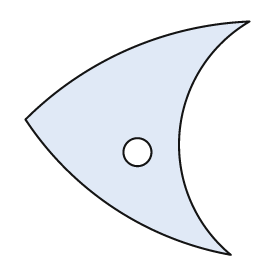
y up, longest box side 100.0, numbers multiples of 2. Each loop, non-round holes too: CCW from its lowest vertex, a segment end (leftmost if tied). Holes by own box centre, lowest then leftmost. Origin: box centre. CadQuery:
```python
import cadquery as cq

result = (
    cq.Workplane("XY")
    .moveTo(40.0, -50.0)
    .threePointArc((18.0, 2.0), (48.0, 50.0))
    .threePointArc((-4.0, 38.0), (-48.0, 8.0))
    .threePointArc((-10.0, -30.0), (40.0, -50.0))
    .close()
    .moveTo(0.0, -6.0)
    .circle(6.0)
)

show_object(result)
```